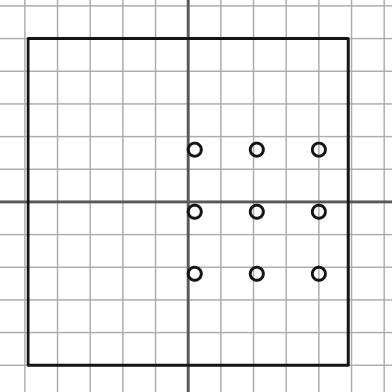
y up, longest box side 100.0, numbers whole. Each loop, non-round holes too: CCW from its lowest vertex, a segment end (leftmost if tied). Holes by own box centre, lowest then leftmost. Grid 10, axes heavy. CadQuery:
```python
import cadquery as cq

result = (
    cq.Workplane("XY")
    .moveTo(-49.0, -50.0)
    .lineTo(49.0, -50.0)
    .lineTo(49.0, 50.0)
    .lineTo(-49.0, 50.0)
    .close()
    .moveTo(2.0, -22.0)
    .circle(2.0)
    .moveTo(21.0, -22.0)
    .circle(2.0)
    .moveTo(40.0, -22.0)
    .circle(2.0)
    .moveTo(2.0, -3.0)
    .circle(2.0)
    .moveTo(21.0, -3.0)
    .circle(2.0)
    .moveTo(40.0, -3.0)
    .circle(2.0)
    .moveTo(2.0, 16.0)
    .circle(2.0)
    .moveTo(21.0, 16.0)
    .circle(2.0)
    .moveTo(40.0, 16.0)
    .circle(2.0)
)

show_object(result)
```